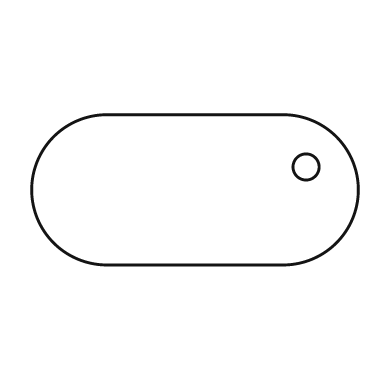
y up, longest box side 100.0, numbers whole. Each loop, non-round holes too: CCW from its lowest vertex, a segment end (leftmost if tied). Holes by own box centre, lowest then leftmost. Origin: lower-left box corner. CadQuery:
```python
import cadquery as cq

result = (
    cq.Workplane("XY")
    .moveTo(23.0, 0.0)
    .lineTo(77.0, 0.0)
    .threePointArc((100.0, 23.0), (77.0, 46.0))
    .lineTo(23.0, 46.0)
    .threePointArc((0.0, 23.0), (23.0, 0.0))
    .close()
    .moveTo(84.0, 30.0)
    .circle(4.0)
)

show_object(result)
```